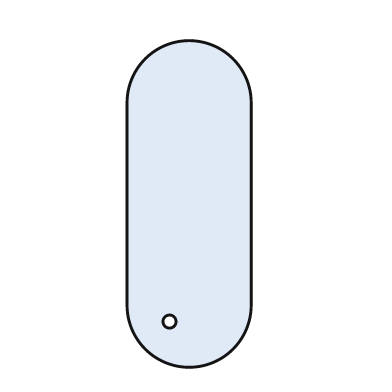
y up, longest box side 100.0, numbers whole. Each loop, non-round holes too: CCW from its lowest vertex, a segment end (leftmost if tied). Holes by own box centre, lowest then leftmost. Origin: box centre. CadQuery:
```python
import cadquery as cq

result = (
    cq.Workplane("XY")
    .moveTo(-19.0, -31.0)
    .threePointArc((0.0, -50.0), (19.0, -31.0))
    .lineTo(19.0, 31.0)
    .threePointArc((0.0, 50.0), (-19.0, 31.0))
    .close()
    .moveTo(-6.0, -36.0)
    .circle(2.0)
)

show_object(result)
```